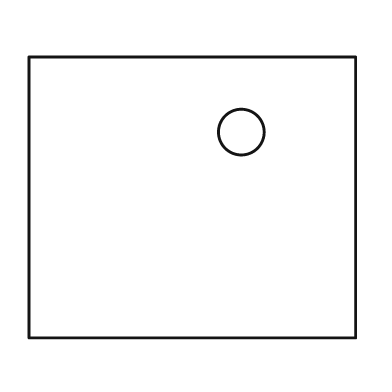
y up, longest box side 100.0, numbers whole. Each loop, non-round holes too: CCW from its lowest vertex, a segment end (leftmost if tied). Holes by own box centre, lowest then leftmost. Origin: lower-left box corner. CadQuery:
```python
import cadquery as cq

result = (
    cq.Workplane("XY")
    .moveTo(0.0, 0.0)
    .lineTo(100.0, 0.0)
    .lineTo(100.0, 86.0)
    .lineTo(0.0, 86.0)
    .close()
    .moveTo(65.0, 63.0)
    .circle(7.0)
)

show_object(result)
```